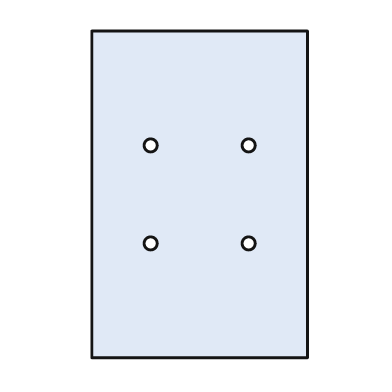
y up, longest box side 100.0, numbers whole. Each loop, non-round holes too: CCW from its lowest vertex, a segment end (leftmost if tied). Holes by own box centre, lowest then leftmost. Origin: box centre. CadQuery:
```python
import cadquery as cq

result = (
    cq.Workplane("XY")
    .moveTo(-33.0, -50.0)
    .lineTo(33.0, -50.0)
    .lineTo(33.0, 50.0)
    .lineTo(-33.0, 50.0)
    .close()
    .moveTo(-15.0, -15.0)
    .circle(2.0)
    .moveTo(15.0, -15.0)
    .circle(2.0)
    .moveTo(-15.0, 15.0)
    .circle(2.0)
    .moveTo(15.0, 15.0)
    .circle(2.0)
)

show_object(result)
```